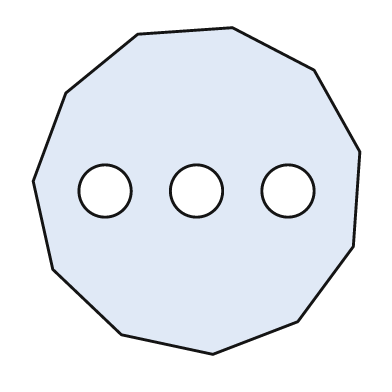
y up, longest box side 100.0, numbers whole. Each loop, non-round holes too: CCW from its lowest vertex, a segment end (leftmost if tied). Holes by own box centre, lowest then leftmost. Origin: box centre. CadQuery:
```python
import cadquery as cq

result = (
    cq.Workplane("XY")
    .moveTo(5.0, -50.0)
    .lineTo(31.0, -40.0)
    .lineTo(48.0, -17.0)
    .lineTo(50.0, 12.0)
    .lineTo(36.0, 37.0)
    .lineTo(11.0, 50.0)
    .lineTo(-18.0, 48.0)
    .lineTo(-40.0, 30.0)
    .lineTo(-50.0, 3.0)
    .lineTo(-44.0, -24.0)
    .lineTo(-23.0, -44.0)
    .close()
    .moveTo(-28.0, 0.0)
    .circle(8.0)
    .moveTo(0.0, 0.0)
    .circle(8.0)
    .moveTo(28.0, 0.0)
    .circle(8.0)
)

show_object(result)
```